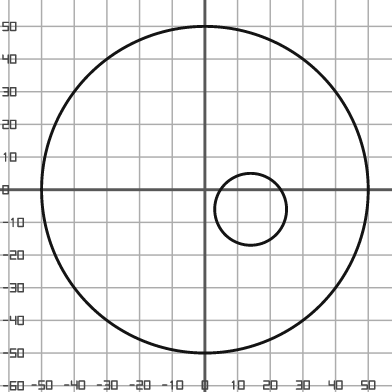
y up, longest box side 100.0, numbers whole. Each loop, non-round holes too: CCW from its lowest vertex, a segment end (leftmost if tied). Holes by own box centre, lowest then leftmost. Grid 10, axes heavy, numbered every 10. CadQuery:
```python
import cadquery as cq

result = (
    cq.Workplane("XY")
    .moveTo(0.0, 0.0)
    .circle(50.0)
    .moveTo(14.0, -6.0)
    .circle(11.0)
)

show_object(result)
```